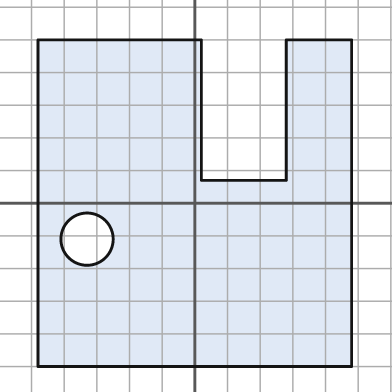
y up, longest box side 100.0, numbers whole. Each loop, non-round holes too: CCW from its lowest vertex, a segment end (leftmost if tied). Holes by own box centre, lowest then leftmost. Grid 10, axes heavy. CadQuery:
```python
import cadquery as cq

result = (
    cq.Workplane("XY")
    .moveTo(-48.0, -50.0)
    .lineTo(48.0, -50.0)
    .lineTo(48.0, 50.0)
    .lineTo(28.0, 50.0)
    .lineTo(28.0, 7.0)
    .lineTo(2.0, 7.0)
    .lineTo(2.0, 50.0)
    .lineTo(-48.0, 50.0)
    .close()
    .moveTo(-33.0, -11.0)
    .circle(8.0)
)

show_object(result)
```